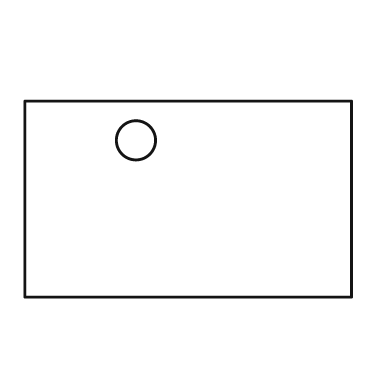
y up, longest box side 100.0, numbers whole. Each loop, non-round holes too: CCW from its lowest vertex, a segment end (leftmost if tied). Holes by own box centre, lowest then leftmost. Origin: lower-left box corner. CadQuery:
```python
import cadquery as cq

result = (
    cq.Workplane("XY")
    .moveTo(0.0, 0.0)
    .lineTo(100.0, 0.0)
    .lineTo(100.0, 60.0)
    .lineTo(0.0, 60.0)
    .close()
    .moveTo(34.0, 48.0)
    .circle(6.0)
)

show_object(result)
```